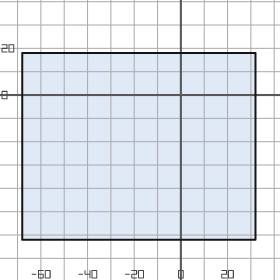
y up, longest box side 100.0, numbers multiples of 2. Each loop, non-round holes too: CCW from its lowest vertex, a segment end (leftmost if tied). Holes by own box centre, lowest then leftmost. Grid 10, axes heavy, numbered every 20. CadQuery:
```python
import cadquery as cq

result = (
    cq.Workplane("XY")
    .moveTo(-68.0, -62.0)
    .lineTo(32.0, -62.0)
    .lineTo(32.0, 18.0)
    .lineTo(-68.0, 18.0)
    .close()
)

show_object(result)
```